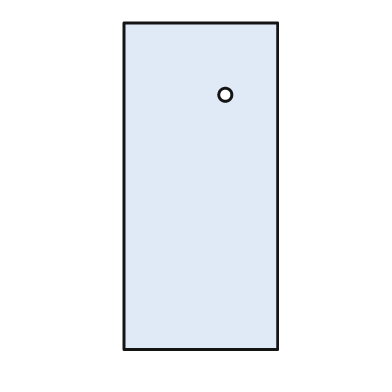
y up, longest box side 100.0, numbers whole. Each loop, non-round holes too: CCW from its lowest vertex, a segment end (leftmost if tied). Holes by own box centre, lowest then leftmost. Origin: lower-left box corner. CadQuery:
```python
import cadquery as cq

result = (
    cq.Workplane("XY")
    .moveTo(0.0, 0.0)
    .lineTo(47.0, 0.0)
    .lineTo(47.0, 100.0)
    .lineTo(0.0, 100.0)
    .close()
    .moveTo(31.0, 78.0)
    .circle(2.0)
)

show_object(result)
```